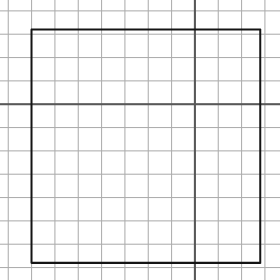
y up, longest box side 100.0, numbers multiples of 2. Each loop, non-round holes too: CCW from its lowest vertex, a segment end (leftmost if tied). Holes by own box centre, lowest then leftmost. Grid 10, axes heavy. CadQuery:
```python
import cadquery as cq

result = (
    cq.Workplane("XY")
    .moveTo(-70.0, -68.0)
    .lineTo(28.0, -68.0)
    .lineTo(28.0, 32.0)
    .lineTo(-70.0, 32.0)
    .close()
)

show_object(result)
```